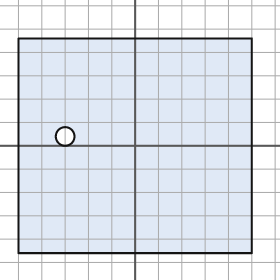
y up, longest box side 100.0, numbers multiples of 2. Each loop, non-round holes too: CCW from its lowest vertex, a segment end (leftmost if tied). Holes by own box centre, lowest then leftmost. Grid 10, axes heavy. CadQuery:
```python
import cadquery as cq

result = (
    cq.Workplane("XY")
    .moveTo(-50.0, -46.0)
    .lineTo(50.0, -46.0)
    .lineTo(50.0, 46.0)
    .lineTo(-50.0, 46.0)
    .close()
    .moveTo(-30.0, 4.0)
    .circle(4.0)
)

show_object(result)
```